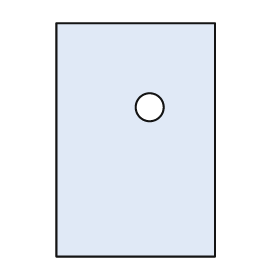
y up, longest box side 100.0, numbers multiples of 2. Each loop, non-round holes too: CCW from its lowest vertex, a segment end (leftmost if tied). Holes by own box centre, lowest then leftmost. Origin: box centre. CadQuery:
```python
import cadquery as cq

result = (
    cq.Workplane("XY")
    .moveTo(-34.0, -50.0)
    .lineTo(34.0, -50.0)
    .lineTo(34.0, 50.0)
    .lineTo(-34.0, 50.0)
    .close()
    .moveTo(6.0, 14.0)
    .circle(6.0)
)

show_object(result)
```